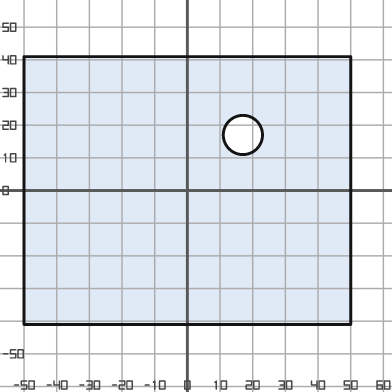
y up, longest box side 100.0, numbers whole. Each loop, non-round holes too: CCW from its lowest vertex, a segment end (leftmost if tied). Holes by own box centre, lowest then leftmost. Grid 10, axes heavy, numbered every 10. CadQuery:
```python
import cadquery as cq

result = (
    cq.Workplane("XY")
    .moveTo(-50.0, -41.0)
    .lineTo(50.0, -41.0)
    .lineTo(50.0, 41.0)
    .lineTo(-50.0, 41.0)
    .close()
    .moveTo(17.0, 17.0)
    .circle(6.0)
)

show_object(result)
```